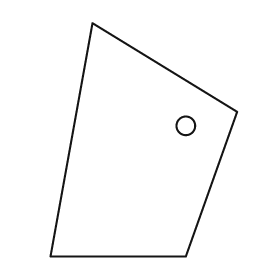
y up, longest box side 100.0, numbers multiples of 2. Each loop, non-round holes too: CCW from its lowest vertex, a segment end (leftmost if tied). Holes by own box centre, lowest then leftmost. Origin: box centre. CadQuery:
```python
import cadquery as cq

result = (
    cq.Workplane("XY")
    .moveTo(-40.0, -50.0)
    .lineTo(18.0, -50.0)
    .lineTo(40.0, 12.0)
    .lineTo(-22.0, 50.0)
    .close()
    .moveTo(18.0, 6.0)
    .circle(4.0)
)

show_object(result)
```